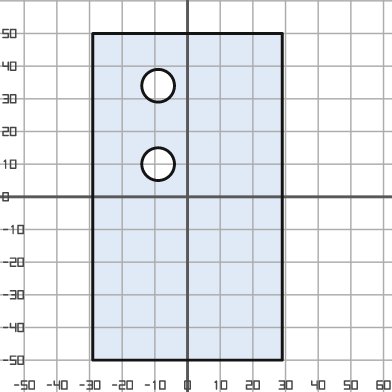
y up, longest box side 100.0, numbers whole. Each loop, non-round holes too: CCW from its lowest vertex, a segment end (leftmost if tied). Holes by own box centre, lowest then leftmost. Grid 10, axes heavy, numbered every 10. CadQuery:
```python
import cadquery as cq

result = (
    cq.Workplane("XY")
    .moveTo(-29.0, -50.0)
    .lineTo(29.0, -50.0)
    .lineTo(29.0, 50.0)
    .lineTo(-29.0, 50.0)
    .close()
    .moveTo(-9.0, 10.0)
    .circle(5.0)
    .moveTo(-9.0, 34.0)
    .circle(5.0)
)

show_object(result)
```